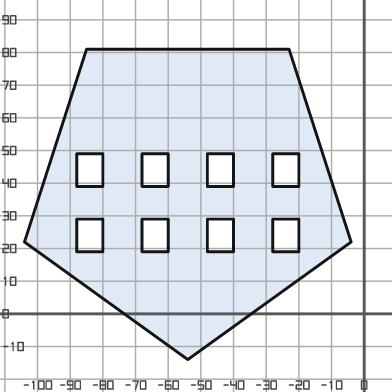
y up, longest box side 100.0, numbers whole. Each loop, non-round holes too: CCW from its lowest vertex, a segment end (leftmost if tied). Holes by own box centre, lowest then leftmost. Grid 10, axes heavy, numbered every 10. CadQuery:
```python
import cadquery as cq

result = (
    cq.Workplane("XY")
    .moveTo(-54.0, -14.0)
    .lineTo(-4.0, 22.0)
    .lineTo(-23.0, 81.0)
    .lineTo(-85.0, 81.0)
    .lineTo(-104.0, 22.0)
    .close()
    .moveTo(-88.0, 19.0)
    .lineTo(-80.0, 19.0)
    .lineTo(-80.0, 29.0)
    .lineTo(-88.0, 29.0)
    .close()
    .moveTo(-68.0, 19.0)
    .lineTo(-60.0, 19.0)
    .lineTo(-60.0, 29.0)
    .lineTo(-68.0, 29.0)
    .close()
    .moveTo(-48.0, 19.0)
    .lineTo(-40.0, 19.0)
    .lineTo(-40.0, 29.0)
    .lineTo(-48.0, 29.0)
    .close()
    .moveTo(-28.0, 19.0)
    .lineTo(-20.0, 19.0)
    .lineTo(-20.0, 29.0)
    .lineTo(-28.0, 29.0)
    .close()
    .moveTo(-88.0, 39.0)
    .lineTo(-80.0, 39.0)
    .lineTo(-80.0, 49.0)
    .lineTo(-88.0, 49.0)
    .close()
    .moveTo(-68.0, 39.0)
    .lineTo(-60.0, 39.0)
    .lineTo(-60.0, 49.0)
    .lineTo(-68.0, 49.0)
    .close()
    .moveTo(-48.0, 39.0)
    .lineTo(-40.0, 39.0)
    .lineTo(-40.0, 49.0)
    .lineTo(-48.0, 49.0)
    .close()
    .moveTo(-28.0, 39.0)
    .lineTo(-20.0, 39.0)
    .lineTo(-20.0, 49.0)
    .lineTo(-28.0, 49.0)
    .close()
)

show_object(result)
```